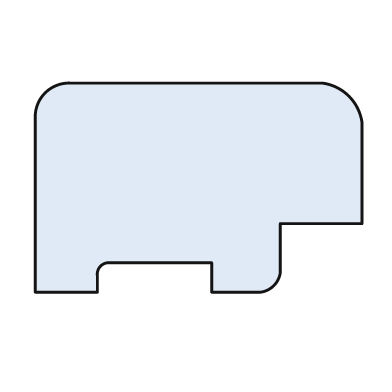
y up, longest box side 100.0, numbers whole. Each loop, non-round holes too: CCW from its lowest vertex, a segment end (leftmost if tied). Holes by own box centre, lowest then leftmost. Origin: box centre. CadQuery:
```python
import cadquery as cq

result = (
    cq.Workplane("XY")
    .moveTo(-50.0, -32.0)
    .lineTo(-31.0, -32.0)
    .lineTo(-31.0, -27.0)
    .threePointArc((-30.0, -24.0), (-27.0, -23.0))
    .lineTo(4.0, -23.0)
    .lineTo(4.0, -32.0)
    .lineTo(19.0, -32.0)
    .threePointArc((23.0, -30.0), (25.0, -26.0))
    .lineTo(25.0, -11.0)
    .lineTo(50.0, -11.0)
    .lineTo(50.0, 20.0)
    .threePointArc((46.0, 28.0), (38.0, 32.0))
    .lineTo(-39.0, 32.0)
    .threePointArc((-47.0, 29.0), (-50.0, 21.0))
    .close()
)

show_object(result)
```